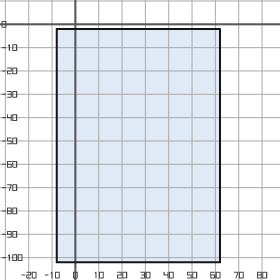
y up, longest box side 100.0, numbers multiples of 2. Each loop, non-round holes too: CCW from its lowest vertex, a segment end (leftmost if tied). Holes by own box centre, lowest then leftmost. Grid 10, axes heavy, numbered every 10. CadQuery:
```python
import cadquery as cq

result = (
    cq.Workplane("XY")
    .moveTo(-8.0, -102.0)
    .lineTo(62.0, -102.0)
    .lineTo(62.0, -2.0)
    .lineTo(-8.0, -2.0)
    .close()
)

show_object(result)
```